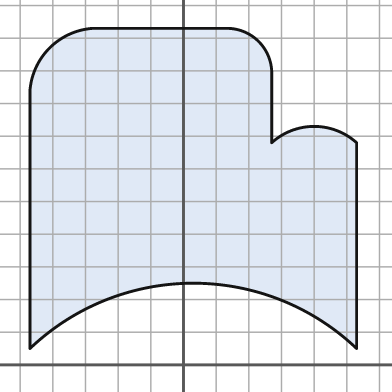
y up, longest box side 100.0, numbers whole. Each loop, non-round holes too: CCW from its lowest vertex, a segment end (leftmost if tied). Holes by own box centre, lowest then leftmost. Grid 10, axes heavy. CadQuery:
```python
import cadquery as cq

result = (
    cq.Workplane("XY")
    .moveTo(-47.0, 5.0)
    .threePointArc((3.0, 25.0), (53.0, 5.0))
    .lineTo(53.0, 68.0)
    .threePointArc((40.0, 73.0), (27.0, 68.0))
    .lineTo(27.0, 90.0)
    .threePointArc((23.0, 99.0), (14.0, 103.0))
    .lineTo(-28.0, 103.0)
    .threePointArc((-41.0, 97.0), (-47.0, 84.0))
    .close()
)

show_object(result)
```